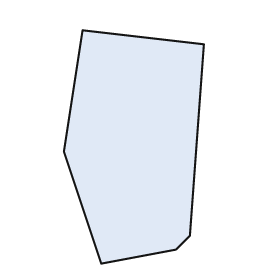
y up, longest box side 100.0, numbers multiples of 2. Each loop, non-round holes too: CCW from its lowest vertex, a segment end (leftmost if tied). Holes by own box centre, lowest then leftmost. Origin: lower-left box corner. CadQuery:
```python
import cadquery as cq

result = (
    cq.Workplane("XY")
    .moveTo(16.0, 0.0)
    .lineTo(48.0, 6.0)
    .lineTo(54.0, 12.0)
    .lineTo(60.0, 94.0)
    .lineTo(8.0, 100.0)
    .lineTo(0.0, 48.0)
    .close()
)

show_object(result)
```